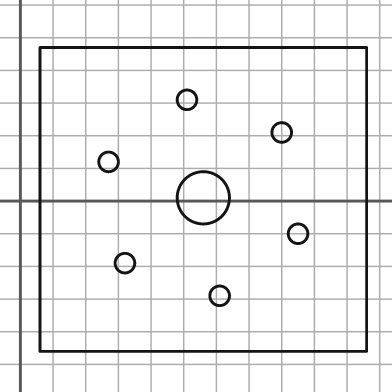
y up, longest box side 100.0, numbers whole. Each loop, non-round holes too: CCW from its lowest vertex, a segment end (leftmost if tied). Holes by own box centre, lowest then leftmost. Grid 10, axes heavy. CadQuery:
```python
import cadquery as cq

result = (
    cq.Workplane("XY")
    .moveTo(6.0, -46.0)
    .lineTo(106.0, -46.0)
    .lineTo(106.0, 47.0)
    .lineTo(6.0, 47.0)
    .close()
    .moveTo(61.0, -29.0)
    .circle(3.0)
    .moveTo(32.0, -19.0)
    .circle(3.0)
    .moveTo(85.0, -10.0)
    .circle(3.0)
    .moveTo(56.0, 1.0)
    .circle(8.0)
    .moveTo(27.0, 12.0)
    .circle(3.0)
    .moveTo(80.0, 21.0)
    .circle(3.0)
    .moveTo(51.0, 31.0)
    .circle(3.0)
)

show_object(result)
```